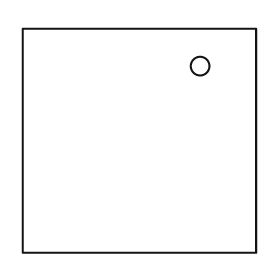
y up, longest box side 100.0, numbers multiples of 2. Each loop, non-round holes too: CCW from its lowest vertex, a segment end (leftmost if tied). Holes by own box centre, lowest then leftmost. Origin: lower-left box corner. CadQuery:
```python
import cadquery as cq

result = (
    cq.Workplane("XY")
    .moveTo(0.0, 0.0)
    .lineTo(100.0, 0.0)
    .lineTo(100.0, 96.0)
    .lineTo(0.0, 96.0)
    .close()
    .moveTo(76.0, 80.0)
    .circle(4.0)
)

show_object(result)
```